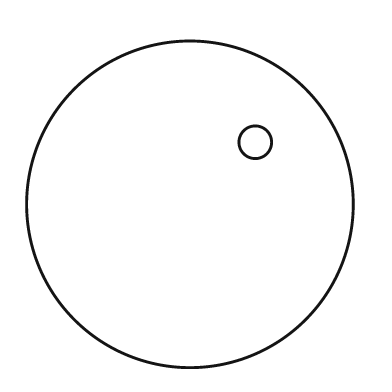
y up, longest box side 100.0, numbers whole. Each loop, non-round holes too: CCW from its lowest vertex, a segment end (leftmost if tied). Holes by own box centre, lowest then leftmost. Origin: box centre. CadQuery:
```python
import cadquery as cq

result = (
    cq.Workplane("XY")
    .moveTo(0.0, 0.0)
    .circle(50.0)
    .moveTo(20.0, 19.0)
    .circle(5.0)
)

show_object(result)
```